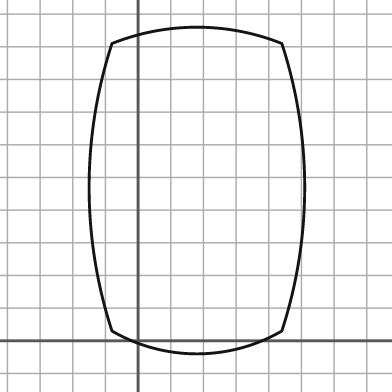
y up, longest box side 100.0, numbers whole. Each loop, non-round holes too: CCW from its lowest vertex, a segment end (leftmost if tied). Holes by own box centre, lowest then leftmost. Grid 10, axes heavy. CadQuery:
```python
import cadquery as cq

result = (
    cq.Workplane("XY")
    .moveTo(-8.0, 3.0)
    .threePointArc((18.0, -4.0), (44.0, 3.0))
    .threePointArc((51.0, 47.0), (44.0, 91.0))
    .threePointArc((18.0, 96.0), (-8.0, 91.0))
    .threePointArc((-15.0, 47.0), (-8.0, 3.0))
    .close()
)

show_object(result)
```